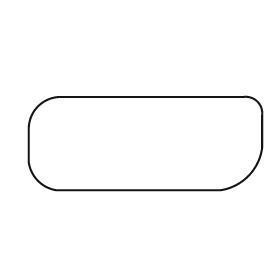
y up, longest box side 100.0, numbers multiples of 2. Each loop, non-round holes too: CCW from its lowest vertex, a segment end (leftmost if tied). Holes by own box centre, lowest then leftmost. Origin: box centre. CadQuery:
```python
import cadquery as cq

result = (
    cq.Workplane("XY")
    .moveTo(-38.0, -20.0)
    .lineTo(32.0, -20.0)
    .threePointArc((44.0, -14.0), (50.0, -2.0))
    .lineTo(50.0, 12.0)
    .threePointArc((48.0, 18.0), (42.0, 20.0))
    .lineTo(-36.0, 20.0)
    .threePointArc((-46.0, 16.0), (-50.0, 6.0))
    .lineTo(-50.0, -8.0)
    .threePointArc((-46.0, -16.0), (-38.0, -20.0))
    .close()
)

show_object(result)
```